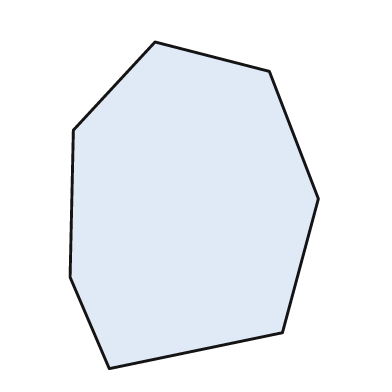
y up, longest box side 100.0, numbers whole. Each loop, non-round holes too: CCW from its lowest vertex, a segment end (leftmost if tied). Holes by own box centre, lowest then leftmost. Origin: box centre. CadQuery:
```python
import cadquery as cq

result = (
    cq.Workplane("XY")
    .moveTo(-26.0, -50.0)
    .lineTo(27.0, -39.0)
    .lineTo(38.0, 2.0)
    .lineTo(23.0, 41.0)
    .lineTo(-12.0, 50.0)
    .lineTo(-37.0, 23.0)
    .lineTo(-38.0, -22.0)
    .close()
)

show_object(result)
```